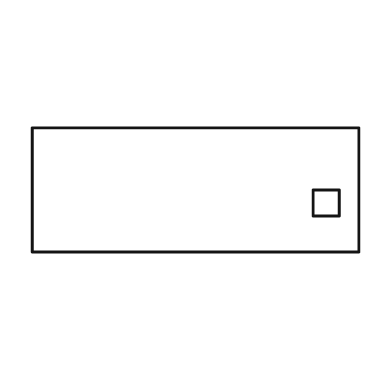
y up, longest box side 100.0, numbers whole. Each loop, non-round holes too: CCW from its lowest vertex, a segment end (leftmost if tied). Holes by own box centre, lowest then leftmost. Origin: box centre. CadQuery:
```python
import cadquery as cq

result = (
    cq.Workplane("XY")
    .moveTo(-50.0, -19.0)
    .lineTo(50.0, -19.0)
    .lineTo(50.0, 19.0)
    .lineTo(-50.0, 19.0)
    .close()
    .moveTo(36.0, -8.0)
    .lineTo(44.0, -8.0)
    .lineTo(44.0, 0.0)
    .lineTo(36.0, 0.0)
    .close()
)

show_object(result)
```